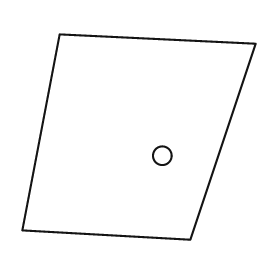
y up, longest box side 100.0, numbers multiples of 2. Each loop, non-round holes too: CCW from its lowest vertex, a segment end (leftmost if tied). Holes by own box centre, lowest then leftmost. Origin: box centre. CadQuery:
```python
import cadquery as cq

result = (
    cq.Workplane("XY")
    .moveTo(22.0, -44.0)
    .lineTo(50.0, 40.0)
    .lineTo(-34.0, 44.0)
    .lineTo(-50.0, -40.0)
    .close()
    .moveTo(10.0, -8.0)
    .circle(4.0)
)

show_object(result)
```